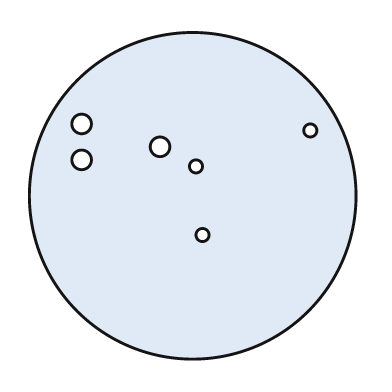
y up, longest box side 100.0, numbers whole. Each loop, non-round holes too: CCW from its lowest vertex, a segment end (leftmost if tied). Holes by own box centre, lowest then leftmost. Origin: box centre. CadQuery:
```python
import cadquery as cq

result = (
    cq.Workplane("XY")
    .moveTo(0.0, 0.0)
    .circle(50.0)
    .moveTo(3.0, -12.0)
    .circle(2.0)
    .moveTo(1.0, 9.0)
    .circle(2.0)
    .moveTo(-34.0, 11.0)
    .circle(3.0)
    .moveTo(-10.0, 15.0)
    .circle(3.0)
    .moveTo(36.0, 20.0)
    .circle(2.0)
    .moveTo(-34.0, 22.0)
    .circle(3.0)
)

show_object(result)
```